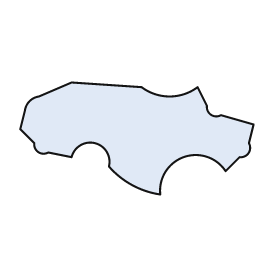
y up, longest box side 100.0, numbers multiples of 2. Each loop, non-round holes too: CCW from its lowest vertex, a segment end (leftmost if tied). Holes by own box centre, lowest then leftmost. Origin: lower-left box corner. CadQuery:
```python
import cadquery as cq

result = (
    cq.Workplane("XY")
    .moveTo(60.0, 0.0)
    .threePointArc((70.0, 16.0), (88.0, 10.0))
    .lineTo(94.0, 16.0)
    .threePointArc((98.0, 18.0), (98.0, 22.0))
    .lineTo(100.0, 30.0)
    .lineTo(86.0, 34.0)
    .threePointArc((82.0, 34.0), (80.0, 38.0))
    .lineTo(76.0, 46.0)
    .threePointArc((64.0, 42.0), (52.0, 46.0))
    .lineTo(22.0, 48.0)
    .lineTo(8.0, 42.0)
    .threePointArc((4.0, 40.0), (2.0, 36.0))
    .lineTo(0.0, 28.0)
    .lineTo(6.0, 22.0)
    .threePointArc((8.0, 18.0), (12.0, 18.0))
    .lineTo(22.0, 16.0)
    .threePointArc((32.0, 22.0), (38.0, 12.0))
    .threePointArc((48.0, 4.0), (60.0, 0.0))
    .close()
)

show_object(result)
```